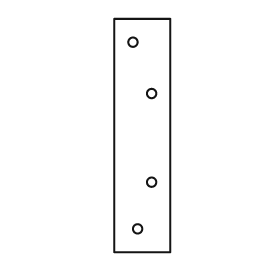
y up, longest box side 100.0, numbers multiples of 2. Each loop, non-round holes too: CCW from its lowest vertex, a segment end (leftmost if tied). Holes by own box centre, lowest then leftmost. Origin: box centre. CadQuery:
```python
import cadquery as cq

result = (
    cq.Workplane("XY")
    .moveTo(-12.0, -50.0)
    .lineTo(12.0, -50.0)
    .lineTo(12.0, 50.0)
    .lineTo(-12.0, 50.0)
    .close()
    .moveTo(-2.0, -40.0)
    .circle(2.0)
    .moveTo(4.0, -20.0)
    .circle(2.0)
    .moveTo(4.0, 18.0)
    .circle(2.0)
    .moveTo(-4.0, 40.0)
    .circle(2.0)
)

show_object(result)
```